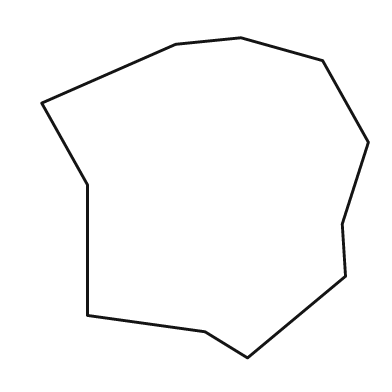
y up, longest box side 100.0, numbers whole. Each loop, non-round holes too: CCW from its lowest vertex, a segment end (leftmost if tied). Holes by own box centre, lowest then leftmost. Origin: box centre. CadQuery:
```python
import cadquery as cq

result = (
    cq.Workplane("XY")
    .moveTo(13.0, -49.0)
    .lineTo(43.0, -24.0)
    .lineTo(42.0, -8.0)
    .lineTo(50.0, 17.0)
    .lineTo(36.0, 42.0)
    .lineTo(11.0, 49.0)
    .lineTo(-9.0, 47.0)
    .lineTo(-50.0, 29.0)
    .lineTo(-36.0, 4.0)
    .lineTo(-36.0, -36.0)
    .lineTo(0.0, -41.0)
    .close()
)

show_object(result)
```